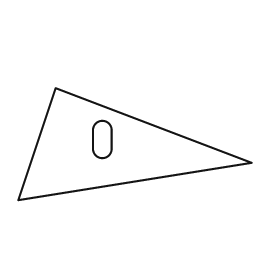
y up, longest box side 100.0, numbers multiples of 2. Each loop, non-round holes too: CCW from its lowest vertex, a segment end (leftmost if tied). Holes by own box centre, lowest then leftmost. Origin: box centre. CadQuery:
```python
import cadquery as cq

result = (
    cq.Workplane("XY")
    .moveTo(-50.0, -24.0)
    .lineTo(50.0, -8.0)
    .lineTo(-34.0, 24.0)
    .close()
    .moveTo(-18.0, -2.0)
    .threePointArc((-14.0, -6.0), (-10.0, -2.0))
    .lineTo(-10.0, 6.0)
    .threePointArc((-14.0, 10.0), (-18.0, 6.0))
    .close()
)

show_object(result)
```